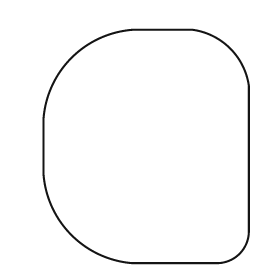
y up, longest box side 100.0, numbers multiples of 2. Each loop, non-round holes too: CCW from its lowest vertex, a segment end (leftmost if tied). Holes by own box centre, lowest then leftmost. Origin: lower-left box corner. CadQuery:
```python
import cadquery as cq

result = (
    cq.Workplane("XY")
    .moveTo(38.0, 0.0)
    .lineTo(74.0, 0.0)
    .threePointArc((84.0, 4.0), (88.0, 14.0))
    .lineTo(88.0, 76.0)
    .threePointArc((80.0, 92.0), (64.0, 100.0))
    .lineTo(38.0, 100.0)
    .threePointArc((12.0, 88.0), (0.0, 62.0))
    .lineTo(0.0, 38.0)
    .threePointArc((12.0, 12.0), (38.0, 0.0))
    .close()
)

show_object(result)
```